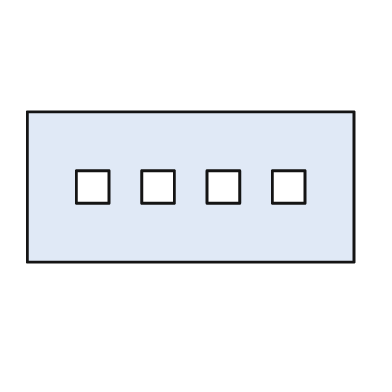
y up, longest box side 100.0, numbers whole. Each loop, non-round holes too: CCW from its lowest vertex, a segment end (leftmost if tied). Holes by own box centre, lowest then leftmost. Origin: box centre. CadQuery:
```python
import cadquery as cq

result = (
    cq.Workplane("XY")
    .moveTo(-50.0, -23.0)
    .lineTo(50.0, -23.0)
    .lineTo(50.0, 23.0)
    .lineTo(-50.0, 23.0)
    .close()
    .moveTo(-35.0, -5.0)
    .lineTo(-25.0, -5.0)
    .lineTo(-25.0, 5.0)
    .lineTo(-35.0, 5.0)
    .close()
    .moveTo(-15.0, -5.0)
    .lineTo(-5.0, -5.0)
    .lineTo(-5.0, 5.0)
    .lineTo(-15.0, 5.0)
    .close()
    .moveTo(5.0, -5.0)
    .lineTo(15.0, -5.0)
    .lineTo(15.0, 5.0)
    .lineTo(5.0, 5.0)
    .close()
    .moveTo(25.0, -5.0)
    .lineTo(35.0, -5.0)
    .lineTo(35.0, 5.0)
    .lineTo(25.0, 5.0)
    .close()
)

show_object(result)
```